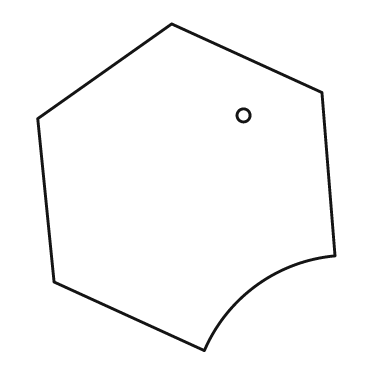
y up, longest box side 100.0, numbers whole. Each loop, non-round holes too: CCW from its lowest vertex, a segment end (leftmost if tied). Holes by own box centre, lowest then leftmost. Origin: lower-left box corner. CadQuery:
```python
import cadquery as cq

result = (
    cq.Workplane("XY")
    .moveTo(51.0, 0.0)
    .threePointArc((67.0, 20.0), (91.0, 29.0))
    .lineTo(87.0, 79.0)
    .lineTo(41.0, 100.0)
    .lineTo(0.0, 71.0)
    .lineTo(5.0, 21.0)
    .close()
    .moveTo(63.0, 72.0)
    .circle(2.0)
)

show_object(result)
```